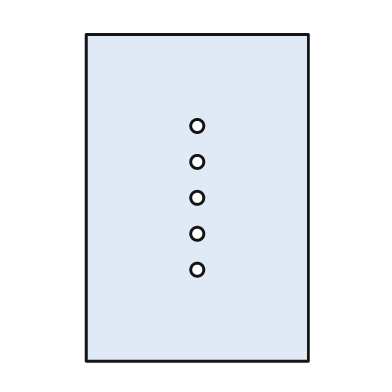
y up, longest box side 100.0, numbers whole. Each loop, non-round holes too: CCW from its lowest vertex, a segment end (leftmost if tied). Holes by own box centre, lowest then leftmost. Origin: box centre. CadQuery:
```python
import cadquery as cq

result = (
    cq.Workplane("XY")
    .moveTo(-34.0, -50.0)
    .lineTo(34.0, -50.0)
    .lineTo(34.0, 50.0)
    .lineTo(-34.0, 50.0)
    .close()
    .moveTo(0.0, -22.0)
    .circle(2.0)
    .moveTo(0.0, -11.0)
    .circle(2.0)
    .moveTo(0.0, 0.0)
    .circle(2.0)
    .moveTo(0.0, 11.0)
    .circle(2.0)
    .moveTo(0.0, 22.0)
    .circle(2.0)
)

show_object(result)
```